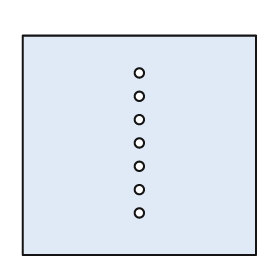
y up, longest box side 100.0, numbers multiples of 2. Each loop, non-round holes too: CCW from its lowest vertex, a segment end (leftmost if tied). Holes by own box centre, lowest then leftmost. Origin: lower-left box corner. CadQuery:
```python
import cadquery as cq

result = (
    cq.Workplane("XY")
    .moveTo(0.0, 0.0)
    .lineTo(100.0, 0.0)
    .lineTo(100.0, 94.0)
    .lineTo(0.0, 94.0)
    .close()
    .moveTo(50.0, 18.0)
    .circle(2.0)
    .moveTo(50.0, 28.0)
    .circle(2.0)
    .moveTo(50.0, 38.0)
    .circle(2.0)
    .moveTo(50.0, 48.0)
    .circle(2.0)
    .moveTo(50.0, 58.0)
    .circle(2.0)
    .moveTo(50.0, 68.0)
    .circle(2.0)
    .moveTo(50.0, 78.0)
    .circle(2.0)
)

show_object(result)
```